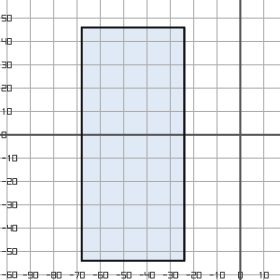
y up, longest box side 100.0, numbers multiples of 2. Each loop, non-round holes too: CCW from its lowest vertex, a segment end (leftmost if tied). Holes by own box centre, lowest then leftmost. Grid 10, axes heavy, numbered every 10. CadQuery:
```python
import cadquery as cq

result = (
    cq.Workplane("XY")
    .moveTo(-68.0, -54.0)
    .lineTo(-24.0, -54.0)
    .lineTo(-24.0, 46.0)
    .lineTo(-68.0, 46.0)
    .close()
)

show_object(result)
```